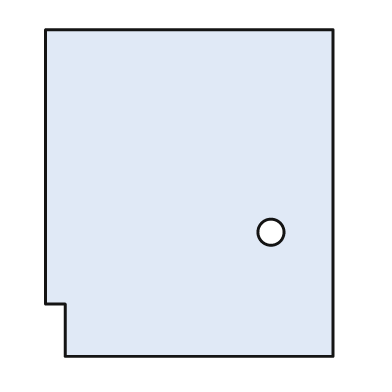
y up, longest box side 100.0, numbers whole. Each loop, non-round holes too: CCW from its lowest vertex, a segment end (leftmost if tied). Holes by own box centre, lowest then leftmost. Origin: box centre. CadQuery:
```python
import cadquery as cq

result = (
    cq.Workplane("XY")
    .moveTo(-38.0, -50.0)
    .lineTo(44.0, -50.0)
    .lineTo(44.0, 50.0)
    .lineTo(-44.0, 50.0)
    .lineTo(-44.0, -34.0)
    .lineTo(-38.0, -34.0)
    .close()
    .moveTo(25.0, -12.0)
    .circle(4.0)
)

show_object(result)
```